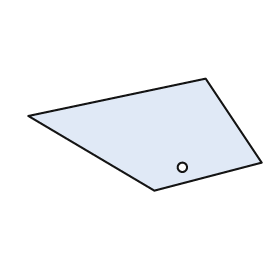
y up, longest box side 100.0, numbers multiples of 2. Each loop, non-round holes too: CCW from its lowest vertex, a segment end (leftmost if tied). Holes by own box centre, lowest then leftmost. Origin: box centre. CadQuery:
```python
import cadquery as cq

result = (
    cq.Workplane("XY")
    .moveTo(4.0, -24.0)
    .lineTo(50.0, -12.0)
    .lineTo(26.0, 24.0)
    .lineTo(-50.0, 8.0)
    .close()
    .moveTo(16.0, -14.0)
    .circle(2.0)
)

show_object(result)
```